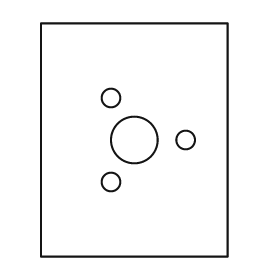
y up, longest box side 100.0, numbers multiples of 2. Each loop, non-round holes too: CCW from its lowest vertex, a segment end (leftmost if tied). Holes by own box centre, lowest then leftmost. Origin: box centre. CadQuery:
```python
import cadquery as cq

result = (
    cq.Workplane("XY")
    .moveTo(-40.0, -50.0)
    .lineTo(40.0, -50.0)
    .lineTo(40.0, 50.0)
    .lineTo(-40.0, 50.0)
    .close()
    .moveTo(-10.0, -18.0)
    .circle(4.0)
    .moveTo(0.0, 0.0)
    .circle(10.0)
    .moveTo(22.0, 0.0)
    .circle(4.0)
    .moveTo(-10.0, 18.0)
    .circle(4.0)
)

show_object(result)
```